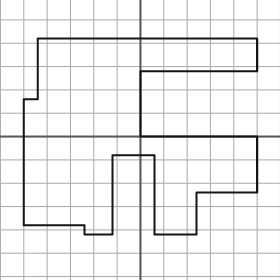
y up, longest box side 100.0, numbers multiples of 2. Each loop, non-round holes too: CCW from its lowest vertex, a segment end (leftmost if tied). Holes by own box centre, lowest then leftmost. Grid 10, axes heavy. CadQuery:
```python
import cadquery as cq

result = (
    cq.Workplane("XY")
    .moveTo(-24.0, -42.0)
    .lineTo(-12.0, -42.0)
    .lineTo(-12.0, -8.0)
    .lineTo(6.0, -8.0)
    .lineTo(6.0, -42.0)
    .lineTo(24.0, -42.0)
    .lineTo(24.0, -24.0)
    .lineTo(50.0, -24.0)
    .lineTo(50.0, 0.0)
    .lineTo(0.0, 0.0)
    .lineTo(0.0, 28.0)
    .lineTo(50.0, 28.0)
    .lineTo(50.0, 42.0)
    .lineTo(-44.0, 42.0)
    .lineTo(-44.0, 16.0)
    .lineTo(-50.0, 16.0)
    .lineTo(-50.0, -38.0)
    .lineTo(-24.0, -38.0)
    .close()
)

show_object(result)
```